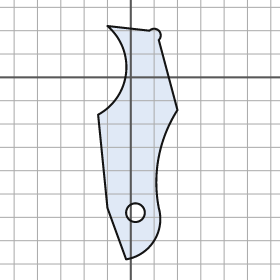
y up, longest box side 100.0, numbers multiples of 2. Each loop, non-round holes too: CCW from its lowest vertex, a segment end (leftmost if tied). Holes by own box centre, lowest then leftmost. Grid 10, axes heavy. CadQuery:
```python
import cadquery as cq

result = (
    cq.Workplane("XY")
    .moveTo(-2.0, -78.0)
    .threePointArc((10.0, -70.0), (12.0, -56.0))
    .threePointArc((12.0, -34.0), (20.0, -14.0))
    .lineTo(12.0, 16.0)
    .threePointArc((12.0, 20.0), (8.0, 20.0))
    .lineTo(-10.0, 22.0)
    .threePointArc((-2.0, 2.0), (-14.0, -16.0))
    .lineTo(-10.0, -56.0)
    .close()
    .moveTo(2.0, -58.0)
    .circle(4.0)
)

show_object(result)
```